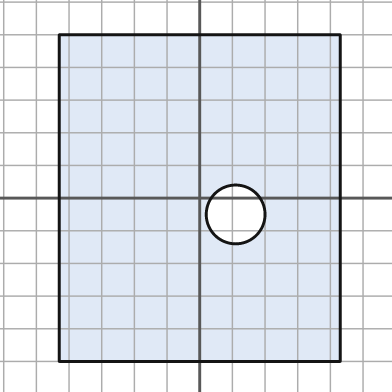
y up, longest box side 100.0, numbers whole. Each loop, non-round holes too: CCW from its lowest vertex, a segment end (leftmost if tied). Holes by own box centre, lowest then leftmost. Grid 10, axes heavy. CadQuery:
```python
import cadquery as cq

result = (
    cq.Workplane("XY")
    .moveTo(-43.0, -50.0)
    .lineTo(43.0, -50.0)
    .lineTo(43.0, 50.0)
    .lineTo(-43.0, 50.0)
    .close()
    .moveTo(11.0, -5.0)
    .circle(9.0)
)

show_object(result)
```